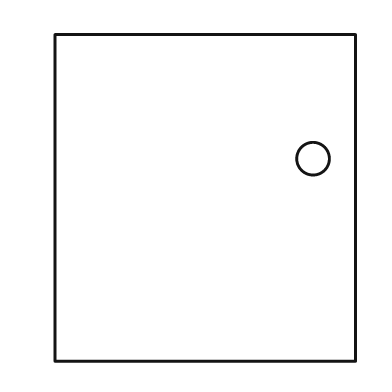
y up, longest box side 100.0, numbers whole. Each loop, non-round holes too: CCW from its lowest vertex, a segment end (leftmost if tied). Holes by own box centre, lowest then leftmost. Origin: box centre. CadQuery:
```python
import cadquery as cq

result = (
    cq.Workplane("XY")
    .moveTo(-46.0, -50.0)
    .lineTo(46.0, -50.0)
    .lineTo(46.0, 50.0)
    .lineTo(-46.0, 50.0)
    .close()
    .moveTo(33.0, 12.0)
    .circle(5.0)
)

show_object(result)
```